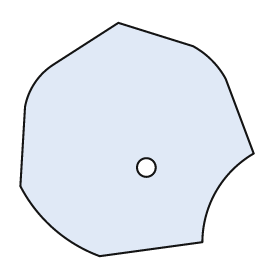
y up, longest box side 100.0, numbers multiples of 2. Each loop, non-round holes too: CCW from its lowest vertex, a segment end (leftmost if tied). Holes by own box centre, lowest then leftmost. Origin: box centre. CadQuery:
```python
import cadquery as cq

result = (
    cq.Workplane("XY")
    .moveTo(-16.0, -50.0)
    .lineTo(28.0, -44.0)
    .threePointArc((34.0, -22.0), (50.0, -6.0))
    .lineTo(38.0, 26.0)
    .threePointArc((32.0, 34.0), (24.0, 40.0))
    .lineTo(-8.0, 50.0)
    .lineTo(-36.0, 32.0)
    .threePointArc((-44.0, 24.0), (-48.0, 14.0))
    .lineTo(-50.0, -20.0)
    .threePointArc((-36.0, -38.0), (-16.0, -50.0))
    .close()
    .moveTo(4.0, -12.0)
    .circle(4.0)
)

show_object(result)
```